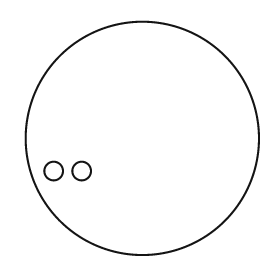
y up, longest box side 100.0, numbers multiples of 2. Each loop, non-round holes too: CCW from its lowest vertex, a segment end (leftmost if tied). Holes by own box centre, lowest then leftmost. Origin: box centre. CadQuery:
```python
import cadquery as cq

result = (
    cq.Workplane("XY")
    .moveTo(0.0, 0.0)
    .circle(50.0)
    .moveTo(-38.0, -14.0)
    .circle(4.0)
    .moveTo(-26.0, -14.0)
    .circle(4.0)
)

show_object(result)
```